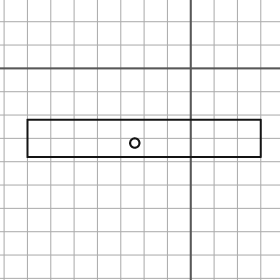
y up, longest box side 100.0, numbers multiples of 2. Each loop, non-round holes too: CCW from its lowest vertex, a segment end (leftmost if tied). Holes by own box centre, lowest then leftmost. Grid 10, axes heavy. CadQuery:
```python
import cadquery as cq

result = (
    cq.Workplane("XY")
    .moveTo(-70.0, -38.0)
    .lineTo(30.0, -38.0)
    .lineTo(30.0, -22.0)
    .lineTo(-70.0, -22.0)
    .close()
    .moveTo(-24.0, -32.0)
    .circle(2.0)
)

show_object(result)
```